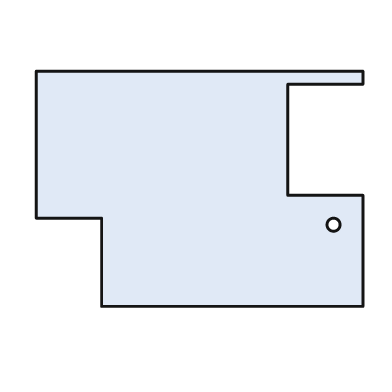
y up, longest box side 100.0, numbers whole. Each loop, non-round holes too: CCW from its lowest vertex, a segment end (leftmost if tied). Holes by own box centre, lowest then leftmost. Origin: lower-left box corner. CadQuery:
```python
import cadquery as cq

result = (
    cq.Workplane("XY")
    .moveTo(20.0, 0.0)
    .lineTo(100.0, 0.0)
    .lineTo(100.0, 34.0)
    .lineTo(77.0, 34.0)
    .lineTo(77.0, 68.0)
    .lineTo(100.0, 68.0)
    .lineTo(100.0, 72.0)
    .lineTo(0.0, 72.0)
    .lineTo(0.0, 27.0)
    .lineTo(20.0, 27.0)
    .close()
    .moveTo(91.0, 25.0)
    .circle(2.0)
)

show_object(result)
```